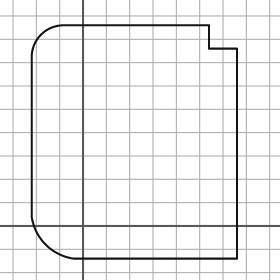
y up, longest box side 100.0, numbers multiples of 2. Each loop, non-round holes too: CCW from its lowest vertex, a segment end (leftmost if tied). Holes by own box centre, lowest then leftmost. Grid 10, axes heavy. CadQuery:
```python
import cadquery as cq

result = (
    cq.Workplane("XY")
    .moveTo(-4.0, -14.0)
    .lineTo(66.0, -14.0)
    .lineTo(66.0, 76.0)
    .lineTo(54.0, 76.0)
    .lineTo(54.0, 86.0)
    .lineTo(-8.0, 86.0)
    .threePointArc((-18.0, 82.0), (-22.0, 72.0))
    .lineTo(-22.0, 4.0)
    .threePointArc((-16.0, -8.0), (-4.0, -14.0))
    .close()
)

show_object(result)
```